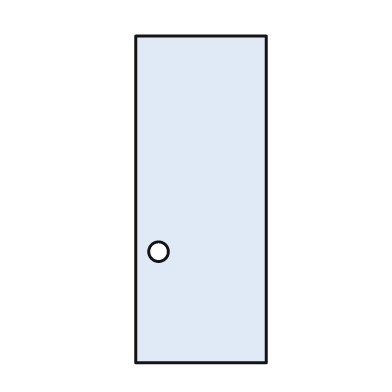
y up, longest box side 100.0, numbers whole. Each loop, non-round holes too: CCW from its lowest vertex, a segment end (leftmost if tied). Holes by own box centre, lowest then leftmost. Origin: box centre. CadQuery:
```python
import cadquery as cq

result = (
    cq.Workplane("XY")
    .moveTo(-20.0, -50.0)
    .lineTo(20.0, -50.0)
    .lineTo(20.0, 50.0)
    .lineTo(-20.0, 50.0)
    .close()
    .moveTo(-13.0, -16.0)
    .circle(3.0)
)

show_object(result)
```